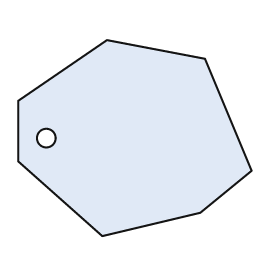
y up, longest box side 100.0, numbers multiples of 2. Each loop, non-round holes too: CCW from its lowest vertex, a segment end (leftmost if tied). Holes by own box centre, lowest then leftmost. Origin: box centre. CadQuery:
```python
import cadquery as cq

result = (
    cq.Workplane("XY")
    .moveTo(-14.0, -42.0)
    .lineTo(28.0, -32.0)
    .lineTo(50.0, -14.0)
    .lineTo(30.0, 34.0)
    .lineTo(-12.0, 42.0)
    .lineTo(-50.0, 16.0)
    .lineTo(-50.0, -10.0)
    .close()
    .moveTo(-38.0, 0.0)
    .circle(4.0)
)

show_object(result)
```